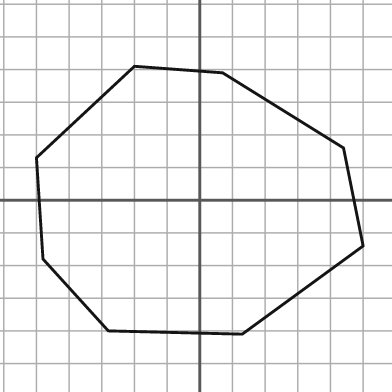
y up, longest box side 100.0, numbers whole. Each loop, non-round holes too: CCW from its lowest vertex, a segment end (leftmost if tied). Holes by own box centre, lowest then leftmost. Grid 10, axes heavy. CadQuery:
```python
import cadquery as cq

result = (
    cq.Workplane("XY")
    .moveTo(13.0, -41.0)
    .lineTo(50.0, -14.0)
    .lineTo(44.0, 16.0)
    .lineTo(7.0, 39.0)
    .lineTo(-20.0, 41.0)
    .lineTo(-50.0, 13.0)
    .lineTo(-48.0, -18.0)
    .lineTo(-28.0, -40.0)
    .close()
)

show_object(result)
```